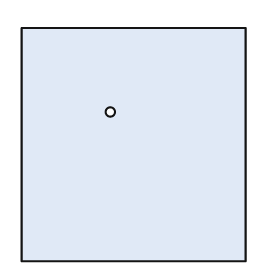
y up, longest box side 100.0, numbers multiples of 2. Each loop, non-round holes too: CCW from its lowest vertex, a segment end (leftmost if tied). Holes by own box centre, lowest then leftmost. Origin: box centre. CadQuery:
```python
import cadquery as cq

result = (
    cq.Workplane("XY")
    .moveTo(-48.0, -50.0)
    .lineTo(48.0, -50.0)
    .lineTo(48.0, 50.0)
    .lineTo(-48.0, 50.0)
    .close()
    .moveTo(-10.0, 14.0)
    .circle(2.0)
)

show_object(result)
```